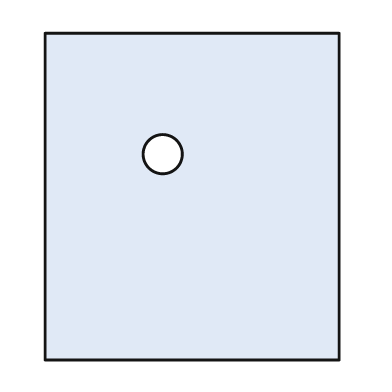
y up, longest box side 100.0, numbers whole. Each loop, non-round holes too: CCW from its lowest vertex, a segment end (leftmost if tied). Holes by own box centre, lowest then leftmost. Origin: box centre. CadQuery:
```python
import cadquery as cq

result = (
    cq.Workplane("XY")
    .moveTo(-45.0, -50.0)
    .lineTo(45.0, -50.0)
    .lineTo(45.0, 50.0)
    .lineTo(-45.0, 50.0)
    .close()
    .moveTo(-9.0, 13.0)
    .circle(6.0)
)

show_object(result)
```